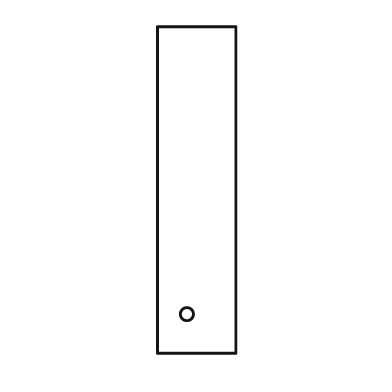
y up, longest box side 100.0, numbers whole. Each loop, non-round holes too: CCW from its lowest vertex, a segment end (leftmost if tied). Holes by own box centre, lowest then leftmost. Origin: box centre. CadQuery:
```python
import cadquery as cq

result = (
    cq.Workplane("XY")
    .moveTo(-12.0, -50.0)
    .lineTo(12.0, -50.0)
    .lineTo(12.0, 50.0)
    .lineTo(-12.0, 50.0)
    .close()
    .moveTo(-3.0, -38.0)
    .circle(2.0)
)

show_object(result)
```